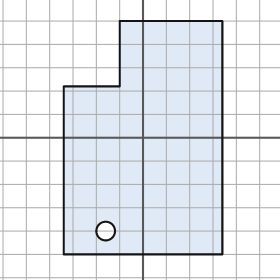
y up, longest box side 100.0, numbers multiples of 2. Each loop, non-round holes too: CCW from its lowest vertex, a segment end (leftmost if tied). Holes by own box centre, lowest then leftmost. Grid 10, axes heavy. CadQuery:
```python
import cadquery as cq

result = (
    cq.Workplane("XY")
    .moveTo(-34.0, -50.0)
    .lineTo(34.0, -50.0)
    .lineTo(34.0, 50.0)
    .lineTo(-10.0, 50.0)
    .lineTo(-10.0, 22.0)
    .lineTo(-34.0, 22.0)
    .close()
    .moveTo(-16.0, -40.0)
    .circle(4.0)
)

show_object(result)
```